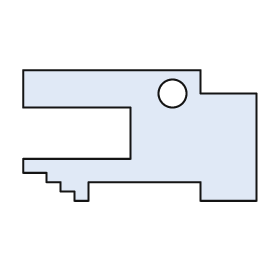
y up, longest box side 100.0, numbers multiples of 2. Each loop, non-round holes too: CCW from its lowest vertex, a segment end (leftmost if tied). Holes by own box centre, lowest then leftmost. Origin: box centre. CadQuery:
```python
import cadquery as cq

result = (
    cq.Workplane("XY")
    .moveTo(-28.0, -28.0)
    .lineTo(-22.0, -28.0)
    .lineTo(-22.0, -20.0)
    .lineTo(26.0, -20.0)
    .lineTo(26.0, -28.0)
    .lineTo(50.0, -28.0)
    .lineTo(50.0, 18.0)
    .lineTo(26.0, 18.0)
    .lineTo(26.0, 28.0)
    .lineTo(-50.0, 28.0)
    .lineTo(-50.0, 12.0)
    .lineTo(-4.0, 12.0)
    .lineTo(-4.0, -10.0)
    .lineTo(-50.0, -10.0)
    .lineTo(-50.0, -16.0)
    .lineTo(-40.0, -16.0)
    .lineTo(-40.0, -20.0)
    .lineTo(-34.0, -20.0)
    .lineTo(-34.0, -24.0)
    .lineTo(-28.0, -24.0)
    .close()
    .moveTo(14.0, 18.0)
    .circle(6.0)
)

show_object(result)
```